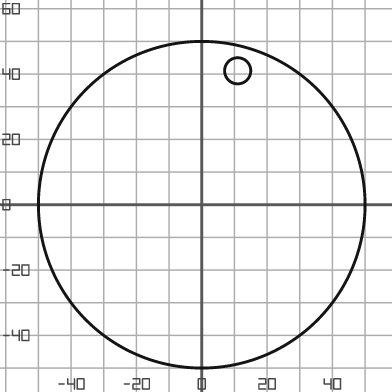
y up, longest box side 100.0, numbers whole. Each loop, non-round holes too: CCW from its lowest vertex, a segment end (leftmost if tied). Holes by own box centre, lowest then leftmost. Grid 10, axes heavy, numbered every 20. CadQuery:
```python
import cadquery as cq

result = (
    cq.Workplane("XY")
    .moveTo(0.0, 0.0)
    .circle(50.0)
    .moveTo(11.0, 41.0)
    .circle(4.0)
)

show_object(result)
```